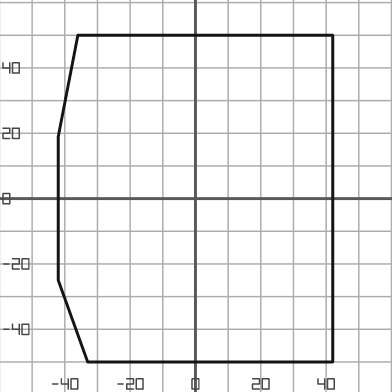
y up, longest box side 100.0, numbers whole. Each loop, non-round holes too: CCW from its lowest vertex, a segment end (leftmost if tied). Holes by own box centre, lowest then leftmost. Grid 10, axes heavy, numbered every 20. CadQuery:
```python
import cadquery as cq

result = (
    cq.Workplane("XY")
    .moveTo(-33.0, -50.0)
    .lineTo(42.0, -50.0)
    .lineTo(42.0, 50.0)
    .lineTo(-36.0, 50.0)
    .lineTo(-42.0, 19.0)
    .lineTo(-42.0, -25.0)
    .close()
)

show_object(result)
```